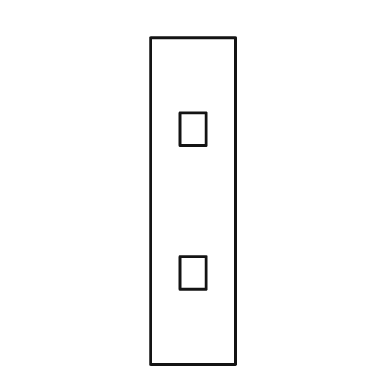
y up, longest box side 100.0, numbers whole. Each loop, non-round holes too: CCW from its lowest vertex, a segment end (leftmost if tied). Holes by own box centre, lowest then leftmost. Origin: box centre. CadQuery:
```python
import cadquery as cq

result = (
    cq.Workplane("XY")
    .moveTo(-13.0, -50.0)
    .lineTo(13.0, -50.0)
    .lineTo(13.0, 50.0)
    .lineTo(-13.0, 50.0)
    .close()
    .moveTo(-4.0, -27.0)
    .lineTo(4.0, -27.0)
    .lineTo(4.0, -17.0)
    .lineTo(-4.0, -17.0)
    .close()
    .moveTo(-4.0, 17.0)
    .lineTo(4.0, 17.0)
    .lineTo(4.0, 27.0)
    .lineTo(-4.0, 27.0)
    .close()
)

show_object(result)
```